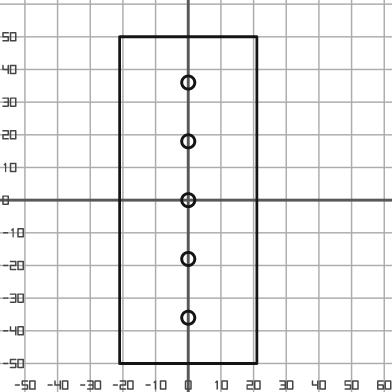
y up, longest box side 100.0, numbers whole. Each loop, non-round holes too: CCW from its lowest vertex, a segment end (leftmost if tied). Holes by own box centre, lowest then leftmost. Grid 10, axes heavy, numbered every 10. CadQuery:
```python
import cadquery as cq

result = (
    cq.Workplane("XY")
    .moveTo(-21.0, -50.0)
    .lineTo(21.0, -50.0)
    .lineTo(21.0, 50.0)
    .lineTo(-21.0, 50.0)
    .close()
    .moveTo(0.0, -36.0)
    .circle(2.0)
    .moveTo(0.0, -18.0)
    .circle(2.0)
    .moveTo(0.0, 0.0)
    .circle(2.0)
    .moveTo(0.0, 18.0)
    .circle(2.0)
    .moveTo(0.0, 36.0)
    .circle(2.0)
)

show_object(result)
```